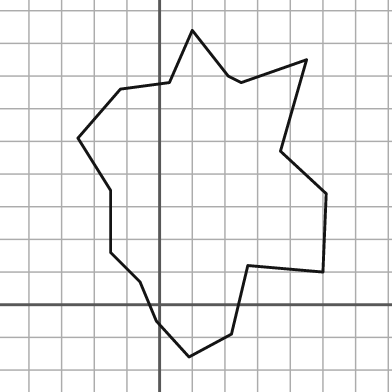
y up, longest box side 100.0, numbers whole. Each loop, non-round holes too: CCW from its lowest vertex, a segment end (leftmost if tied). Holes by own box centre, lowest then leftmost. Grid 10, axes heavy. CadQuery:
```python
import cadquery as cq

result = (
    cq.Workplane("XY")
    .moveTo(9.0, -16.0)
    .lineTo(22.0, -9.0)
    .lineTo(27.0, 12.0)
    .lineTo(50.0, 10.0)
    .lineTo(51.0, 34.0)
    .lineTo(37.0, 47.0)
    .lineTo(45.0, 75.0)
    .lineTo(25.0, 68.0)
    .lineTo(21.0, 70.0)
    .lineTo(10.0, 84.0)
    .lineTo(3.0, 68.0)
    .lineTo(-12.0, 66.0)
    .lineTo(-25.0, 51.0)
    .lineTo(-15.0, 35.0)
    .lineTo(-15.0, 16.0)
    .lineTo(-6.0, 7.0)
    .lineTo(-1.0, -5.0)
    .close()
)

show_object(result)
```